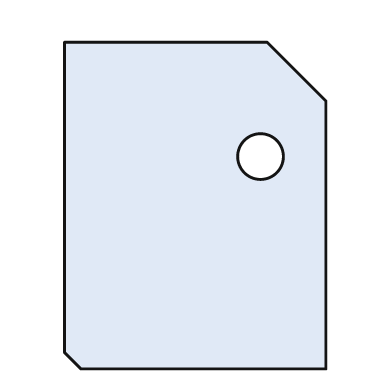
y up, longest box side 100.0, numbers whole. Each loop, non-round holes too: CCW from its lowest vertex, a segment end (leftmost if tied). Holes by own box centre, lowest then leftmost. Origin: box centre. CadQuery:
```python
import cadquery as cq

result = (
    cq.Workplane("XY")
    .moveTo(-35.0, -50.0)
    .lineTo(40.0, -50.0)
    .lineTo(40.0, 32.0)
    .lineTo(22.0, 50.0)
    .lineTo(-40.0, 50.0)
    .lineTo(-40.0, -45.0)
    .close()
    .moveTo(20.0, 15.0)
    .circle(7.0)
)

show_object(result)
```